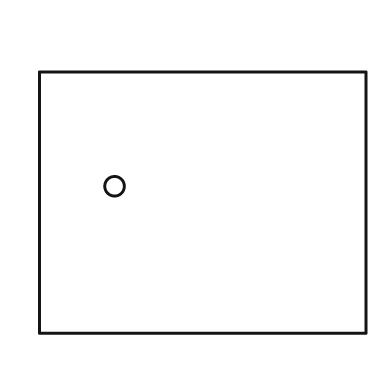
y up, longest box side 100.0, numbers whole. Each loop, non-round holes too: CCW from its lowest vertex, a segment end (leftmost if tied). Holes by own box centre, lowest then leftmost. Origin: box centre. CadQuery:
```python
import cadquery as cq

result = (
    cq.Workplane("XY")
    .moveTo(-50.0, -40.0)
    .lineTo(50.0, -40.0)
    .lineTo(50.0, 40.0)
    .lineTo(-50.0, 40.0)
    .close()
    .moveTo(-27.0, 5.0)
    .circle(3.0)
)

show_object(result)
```